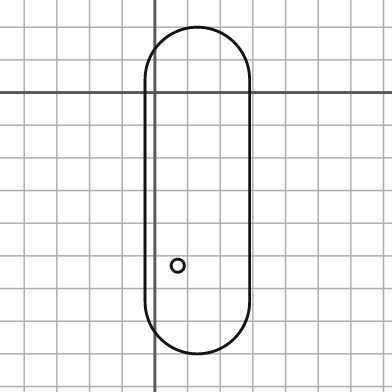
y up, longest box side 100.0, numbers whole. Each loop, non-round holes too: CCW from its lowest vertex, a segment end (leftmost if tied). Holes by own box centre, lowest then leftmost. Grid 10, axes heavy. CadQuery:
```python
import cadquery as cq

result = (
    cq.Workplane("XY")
    .moveTo(-3.0, -64.0)
    .threePointArc((13.0, -80.0), (29.0, -64.0))
    .lineTo(29.0, 4.0)
    .threePointArc((13.0, 20.0), (-3.0, 4.0))
    .close()
    .moveTo(7.0, -53.0)
    .circle(2.0)
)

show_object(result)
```